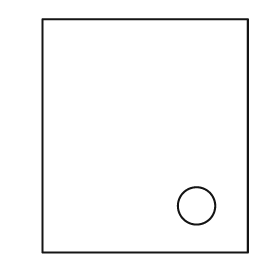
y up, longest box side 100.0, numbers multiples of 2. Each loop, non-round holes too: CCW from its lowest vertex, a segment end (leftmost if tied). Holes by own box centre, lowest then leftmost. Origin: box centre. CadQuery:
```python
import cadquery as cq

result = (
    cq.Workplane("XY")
    .moveTo(-44.0, -50.0)
    .lineTo(44.0, -50.0)
    .lineTo(44.0, 50.0)
    .lineTo(-44.0, 50.0)
    .close()
    .moveTo(22.0, -30.0)
    .circle(8.0)
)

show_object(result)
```